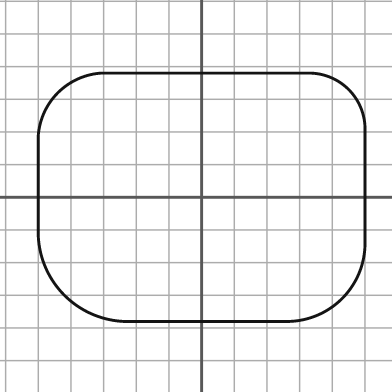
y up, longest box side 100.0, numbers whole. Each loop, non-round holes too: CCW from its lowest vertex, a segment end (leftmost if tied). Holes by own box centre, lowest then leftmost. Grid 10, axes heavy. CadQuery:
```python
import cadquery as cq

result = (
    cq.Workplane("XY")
    .moveTo(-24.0, -38.0)
    .lineTo(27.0, -38.0)
    .threePointArc((43.0, -31.0), (50.0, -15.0))
    .lineTo(50.0, 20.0)
    .threePointArc((45.0, 33.0), (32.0, 38.0))
    .lineTo(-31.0, 38.0)
    .threePointArc((-44.0, 32.0), (-50.0, 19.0))
    .lineTo(-50.0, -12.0)
    .threePointArc((-42.0, -30.0), (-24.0, -38.0))
    .close()
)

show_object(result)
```